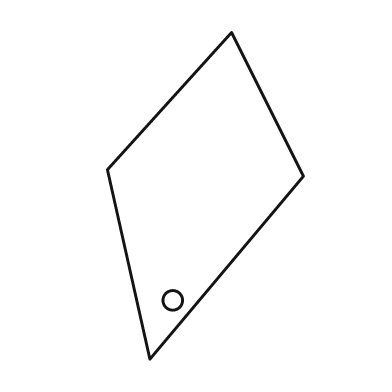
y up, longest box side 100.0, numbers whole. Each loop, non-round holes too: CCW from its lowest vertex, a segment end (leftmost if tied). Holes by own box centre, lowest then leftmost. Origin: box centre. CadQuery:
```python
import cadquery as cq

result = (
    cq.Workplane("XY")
    .moveTo(-17.0, -50.0)
    .lineTo(30.0, 6.0)
    .lineTo(8.0, 50.0)
    .lineTo(-30.0, 8.0)
    .close()
    .moveTo(-10.0, -32.0)
    .circle(3.0)
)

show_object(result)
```